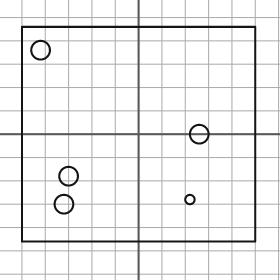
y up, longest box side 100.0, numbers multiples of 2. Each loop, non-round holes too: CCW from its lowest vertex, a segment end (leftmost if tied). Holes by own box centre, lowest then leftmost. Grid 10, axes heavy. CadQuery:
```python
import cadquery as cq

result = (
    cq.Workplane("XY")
    .moveTo(-50.0, -46.0)
    .lineTo(50.0, -46.0)
    .lineTo(50.0, 46.0)
    .lineTo(-50.0, 46.0)
    .close()
    .moveTo(-32.0, -30.0)
    .circle(4.0)
    .moveTo(22.0, -28.0)
    .circle(2.0)
    .moveTo(-30.0, -18.0)
    .circle(4.0)
    .moveTo(26.0, 0.0)
    .circle(4.0)
    .moveTo(-42.0, 36.0)
    .circle(4.0)
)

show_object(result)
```